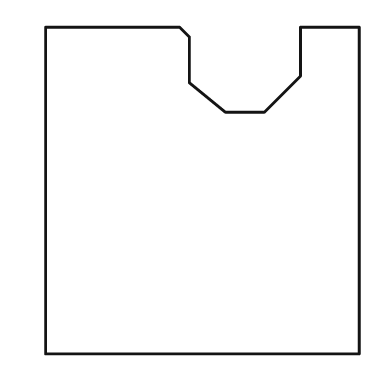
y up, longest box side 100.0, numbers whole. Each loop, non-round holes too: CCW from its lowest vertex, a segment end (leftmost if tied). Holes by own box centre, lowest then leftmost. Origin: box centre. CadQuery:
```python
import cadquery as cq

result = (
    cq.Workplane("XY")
    .moveTo(-48.0, -50.0)
    .lineTo(48.0, -50.0)
    .lineTo(48.0, 50.0)
    .lineTo(30.0, 50.0)
    .lineTo(30.0, 35.0)
    .lineTo(19.0, 24.0)
    .lineTo(7.0, 24.0)
    .lineTo(-4.0, 33.0)
    .lineTo(-4.0, 47.0)
    .lineTo(-7.0, 50.0)
    .lineTo(-48.0, 50.0)
    .close()
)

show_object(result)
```